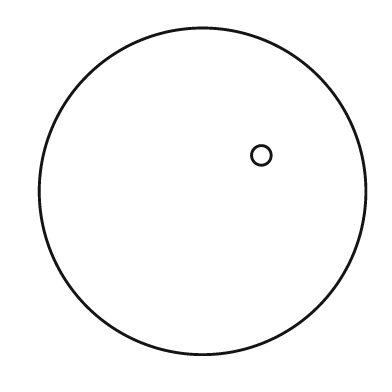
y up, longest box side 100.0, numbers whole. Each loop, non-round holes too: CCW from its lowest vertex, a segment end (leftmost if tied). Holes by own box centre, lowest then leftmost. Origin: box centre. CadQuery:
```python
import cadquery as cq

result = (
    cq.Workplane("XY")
    .moveTo(0.0, 0.0)
    .circle(50.0)
    .moveTo(18.0, 11.0)
    .circle(3.0)
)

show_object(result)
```